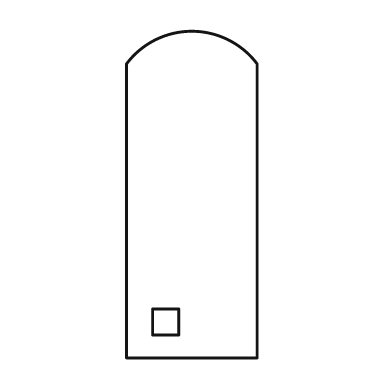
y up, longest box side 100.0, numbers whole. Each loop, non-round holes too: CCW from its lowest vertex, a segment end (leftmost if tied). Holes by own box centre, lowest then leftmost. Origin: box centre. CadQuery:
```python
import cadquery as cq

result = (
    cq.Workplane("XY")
    .moveTo(-20.0, -50.0)
    .lineTo(20.0, -50.0)
    .lineTo(20.0, 40.0)
    .threePointArc((0.0, 50.0), (-20.0, 40.0))
    .close()
    .moveTo(-12.0, -43.0)
    .lineTo(-4.0, -43.0)
    .lineTo(-4.0, -35.0)
    .lineTo(-12.0, -35.0)
    .close()
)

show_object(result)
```